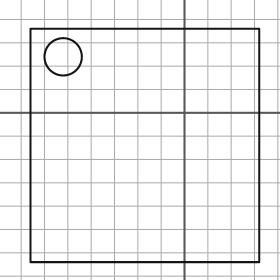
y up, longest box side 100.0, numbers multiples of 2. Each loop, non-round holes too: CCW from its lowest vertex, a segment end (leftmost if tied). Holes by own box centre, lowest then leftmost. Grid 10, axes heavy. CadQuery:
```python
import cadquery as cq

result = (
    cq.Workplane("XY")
    .moveTo(-66.0, -64.0)
    .lineTo(32.0, -64.0)
    .lineTo(32.0, 36.0)
    .lineTo(-66.0, 36.0)
    .close()
    .moveTo(-52.0, 24.0)
    .circle(8.0)
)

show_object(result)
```